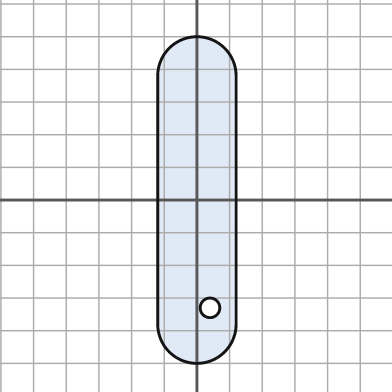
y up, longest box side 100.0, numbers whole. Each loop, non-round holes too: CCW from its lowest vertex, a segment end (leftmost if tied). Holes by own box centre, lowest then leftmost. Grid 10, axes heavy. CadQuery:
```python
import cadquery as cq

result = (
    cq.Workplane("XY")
    .moveTo(-12.0, -38.0)
    .threePointArc((0.0, -50.0), (12.0, -38.0))
    .lineTo(12.0, 38.0)
    .threePointArc((0.0, 50.0), (-12.0, 38.0))
    .close()
    .moveTo(4.0, -33.0)
    .circle(3.0)
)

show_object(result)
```